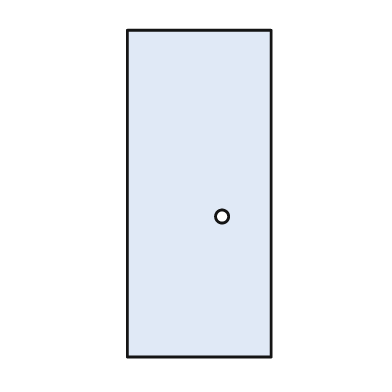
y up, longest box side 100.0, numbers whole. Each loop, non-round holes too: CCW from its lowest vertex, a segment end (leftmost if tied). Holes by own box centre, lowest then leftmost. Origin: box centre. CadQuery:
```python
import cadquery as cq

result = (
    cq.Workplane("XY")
    .moveTo(-22.0, -50.0)
    .lineTo(22.0, -50.0)
    .lineTo(22.0, 50.0)
    .lineTo(-22.0, 50.0)
    .close()
    .moveTo(7.0, -7.0)
    .circle(2.0)
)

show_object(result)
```